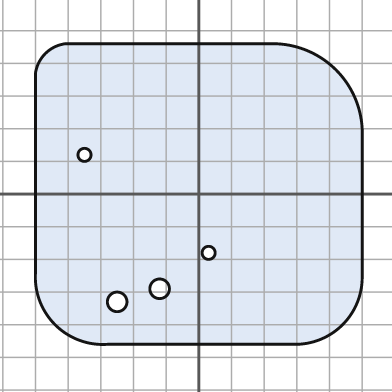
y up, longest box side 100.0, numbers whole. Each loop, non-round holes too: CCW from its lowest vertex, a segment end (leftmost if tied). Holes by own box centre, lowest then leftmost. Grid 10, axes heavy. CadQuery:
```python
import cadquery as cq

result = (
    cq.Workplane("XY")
    .moveTo(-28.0, -46.0)
    .lineTo(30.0, -46.0)
    .threePointArc((44.0, -40.0), (50.0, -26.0))
    .lineTo(50.0, 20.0)
    .threePointArc((42.0, 38.0), (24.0, 46.0))
    .lineTo(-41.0, 46.0)
    .threePointArc((-47.0, 43.0), (-50.0, 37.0))
    .lineTo(-50.0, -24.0)
    .threePointArc((-44.0, -40.0), (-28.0, -46.0))
    .close()
    .moveTo(-25.0, -33.0)
    .circle(3.0)
    .moveTo(-12.0, -29.0)
    .circle(3.0)
    .moveTo(3.0, -18.0)
    .circle(2.0)
    .moveTo(-35.0, 12.0)
    .circle(2.0)
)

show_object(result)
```